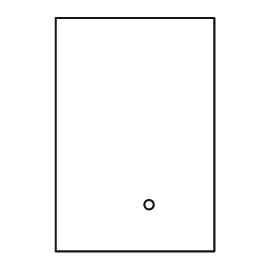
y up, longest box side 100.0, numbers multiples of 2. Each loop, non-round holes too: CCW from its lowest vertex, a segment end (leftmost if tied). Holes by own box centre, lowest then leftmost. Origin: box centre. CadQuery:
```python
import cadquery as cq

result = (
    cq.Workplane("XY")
    .moveTo(-34.0, -50.0)
    .lineTo(34.0, -50.0)
    .lineTo(34.0, 50.0)
    .lineTo(-34.0, 50.0)
    .close()
    .moveTo(6.0, -30.0)
    .circle(2.0)
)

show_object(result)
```